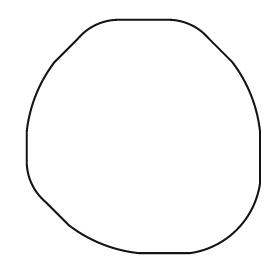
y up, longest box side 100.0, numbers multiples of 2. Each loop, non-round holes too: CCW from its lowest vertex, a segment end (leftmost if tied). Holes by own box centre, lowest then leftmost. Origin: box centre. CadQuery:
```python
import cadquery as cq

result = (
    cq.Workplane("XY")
    .moveTo(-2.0, -50.0)
    .lineTo(20.0, -50.0)
    .threePointArc((40.0, -40.0), (50.0, -20.0))
    .lineTo(50.0, 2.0)
    .threePointArc((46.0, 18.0), (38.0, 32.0))
    .lineTo(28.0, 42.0)
    .threePointArc((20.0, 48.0), (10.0, 50.0))
    .lineTo(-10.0, 50.0)
    .threePointArc((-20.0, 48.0), (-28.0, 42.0))
    .lineTo(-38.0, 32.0)
    .threePointArc((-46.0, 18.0), (-50.0, 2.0))
    .lineTo(-50.0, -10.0)
    .threePointArc((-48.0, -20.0), (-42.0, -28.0))
    .lineTo(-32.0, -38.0)
    .threePointArc((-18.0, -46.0), (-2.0, -50.0))
    .close()
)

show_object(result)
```